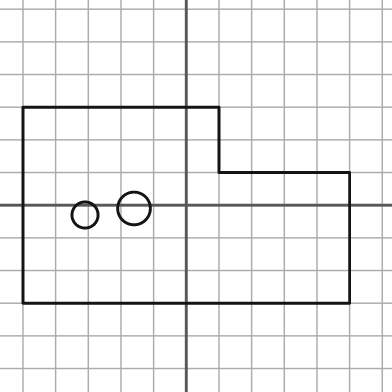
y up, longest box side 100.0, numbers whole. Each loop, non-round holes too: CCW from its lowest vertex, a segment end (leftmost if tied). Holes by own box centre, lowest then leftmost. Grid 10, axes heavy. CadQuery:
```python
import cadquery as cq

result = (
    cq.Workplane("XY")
    .moveTo(-50.0, -30.0)
    .lineTo(50.0, -30.0)
    .lineTo(50.0, 10.0)
    .lineTo(10.0, 10.0)
    .lineTo(10.0, 30.0)
    .lineTo(-50.0, 30.0)
    .close()
    .moveTo(-31.0, -3.0)
    .circle(4.0)
    .moveTo(-16.0, -1.0)
    .circle(5.0)
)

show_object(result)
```